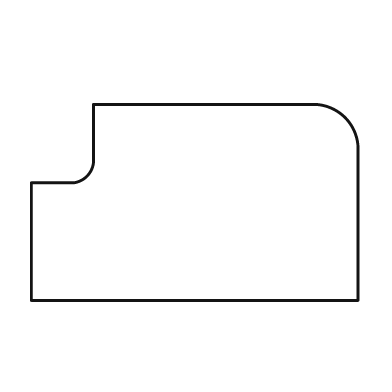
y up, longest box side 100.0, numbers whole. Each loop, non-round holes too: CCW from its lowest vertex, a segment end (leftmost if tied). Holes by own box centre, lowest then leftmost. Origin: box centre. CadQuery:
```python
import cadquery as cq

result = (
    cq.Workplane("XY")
    .moveTo(-50.0, -30.0)
    .lineTo(50.0, -30.0)
    .lineTo(50.0, 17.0)
    .threePointArc((46.0, 26.0), (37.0, 30.0))
    .lineTo(-31.0, 30.0)
    .lineTo(-31.0, 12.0)
    .threePointArc((-33.0, 8.0), (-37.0, 6.0))
    .lineTo(-50.0, 6.0)
    .close()
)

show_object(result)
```